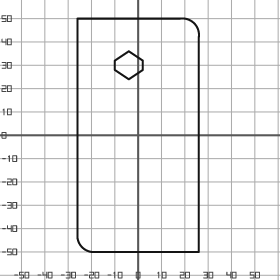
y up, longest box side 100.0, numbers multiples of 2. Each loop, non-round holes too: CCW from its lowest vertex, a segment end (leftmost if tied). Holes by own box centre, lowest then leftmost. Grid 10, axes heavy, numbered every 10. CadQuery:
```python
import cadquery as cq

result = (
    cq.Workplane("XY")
    .moveTo(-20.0, -50.0)
    .lineTo(26.0, -50.0)
    .lineTo(26.0, 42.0)
    .threePointArc((24.0, 48.0), (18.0, 50.0))
    .lineTo(-26.0, 50.0)
    .lineTo(-26.0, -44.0)
    .threePointArc((-24.0, -48.0), (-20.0, -50.0))
    .close()
    .moveTo(-4.0, 24.0)
    .lineTo(2.0, 28.0)
    .lineTo(2.0, 32.0)
    .lineTo(-4.0, 36.0)
    .lineTo(-10.0, 32.0)
    .lineTo(-10.0, 28.0)
    .close()
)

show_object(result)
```